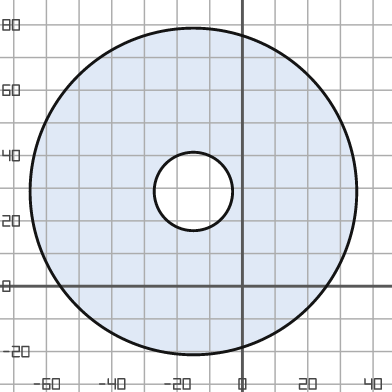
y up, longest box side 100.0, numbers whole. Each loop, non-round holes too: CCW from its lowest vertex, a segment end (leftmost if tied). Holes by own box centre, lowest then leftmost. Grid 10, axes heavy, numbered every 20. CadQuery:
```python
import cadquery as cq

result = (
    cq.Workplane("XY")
    .moveTo(-15.0, 29.0)
    .circle(50.0)
    .moveTo(-15.0, 29.0)
    .circle(12.0)
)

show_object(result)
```